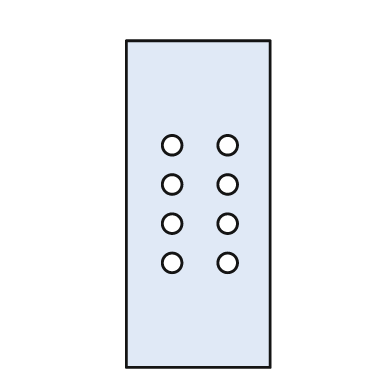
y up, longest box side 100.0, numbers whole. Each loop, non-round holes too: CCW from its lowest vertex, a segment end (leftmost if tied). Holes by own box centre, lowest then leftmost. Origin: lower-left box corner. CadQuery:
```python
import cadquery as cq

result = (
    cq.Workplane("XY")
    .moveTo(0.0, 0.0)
    .lineTo(44.0, 0.0)
    .lineTo(44.0, 100.0)
    .lineTo(0.0, 100.0)
    .close()
    .moveTo(14.0, 32.0)
    .circle(3.0)
    .moveTo(31.0, 32.0)
    .circle(3.0)
    .moveTo(14.0, 44.0)
    .circle(3.0)
    .moveTo(31.0, 44.0)
    .circle(3.0)
    .moveTo(14.0, 56.0)
    .circle(3.0)
    .moveTo(31.0, 56.0)
    .circle(3.0)
    .moveTo(14.0, 68.0)
    .circle(3.0)
    .moveTo(31.0, 68.0)
    .circle(3.0)
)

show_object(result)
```